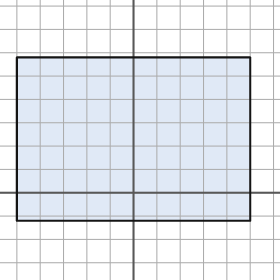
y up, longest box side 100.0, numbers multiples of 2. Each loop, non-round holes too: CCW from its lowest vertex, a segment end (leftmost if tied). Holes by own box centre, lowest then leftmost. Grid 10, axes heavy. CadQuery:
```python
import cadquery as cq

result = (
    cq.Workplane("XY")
    .moveTo(-50.0, -12.0)
    .lineTo(50.0, -12.0)
    .lineTo(50.0, 58.0)
    .lineTo(-50.0, 58.0)
    .close()
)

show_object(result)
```